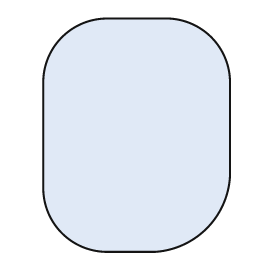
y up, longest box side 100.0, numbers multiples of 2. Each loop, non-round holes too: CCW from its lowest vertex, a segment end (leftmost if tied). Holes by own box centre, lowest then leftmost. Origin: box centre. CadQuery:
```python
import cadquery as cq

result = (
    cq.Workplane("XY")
    .moveTo(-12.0, -50.0)
    .lineTo(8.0, -50.0)
    .threePointArc((30.0, -40.0), (40.0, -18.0))
    .lineTo(40.0, 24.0)
    .threePointArc((32.0, 42.0), (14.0, 50.0))
    .lineTo(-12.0, 50.0)
    .threePointArc((-32.0, 42.0), (-40.0, 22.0))
    .lineTo(-40.0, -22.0)
    .threePointArc((-32.0, -42.0), (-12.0, -50.0))
    .close()
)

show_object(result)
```